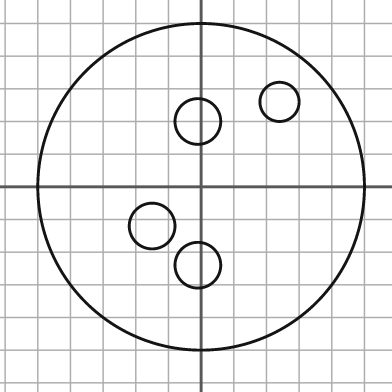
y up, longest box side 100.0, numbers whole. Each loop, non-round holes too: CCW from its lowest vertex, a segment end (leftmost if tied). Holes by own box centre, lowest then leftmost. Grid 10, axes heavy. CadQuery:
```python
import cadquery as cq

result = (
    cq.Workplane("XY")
    .moveTo(0.0, 0.0)
    .circle(50.0)
    .moveTo(-1.0, -24.0)
    .circle(7.0)
    .moveTo(-15.0, -12.0)
    .circle(7.0)
    .moveTo(-1.0, 20.0)
    .circle(7.0)
    .moveTo(24.0, 26.0)
    .circle(6.0)
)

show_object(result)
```